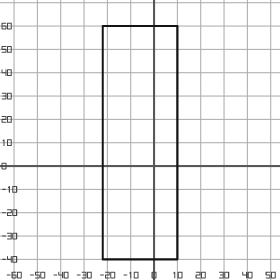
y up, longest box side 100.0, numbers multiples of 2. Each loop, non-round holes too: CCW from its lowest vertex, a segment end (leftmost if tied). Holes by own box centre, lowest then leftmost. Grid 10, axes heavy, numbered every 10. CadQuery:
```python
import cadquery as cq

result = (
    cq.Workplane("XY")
    .moveTo(-22.0, -40.0)
    .lineTo(10.0, -40.0)
    .lineTo(10.0, 60.0)
    .lineTo(-22.0, 60.0)
    .close()
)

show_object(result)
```